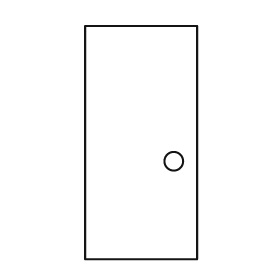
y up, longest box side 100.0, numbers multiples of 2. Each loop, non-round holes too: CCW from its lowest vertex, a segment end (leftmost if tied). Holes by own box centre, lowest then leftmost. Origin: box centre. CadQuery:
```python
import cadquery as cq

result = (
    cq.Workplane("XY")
    .moveTo(-24.0, -50.0)
    .lineTo(24.0, -50.0)
    .lineTo(24.0, 50.0)
    .lineTo(-24.0, 50.0)
    .close()
    .moveTo(14.0, -8.0)
    .circle(4.0)
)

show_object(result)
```